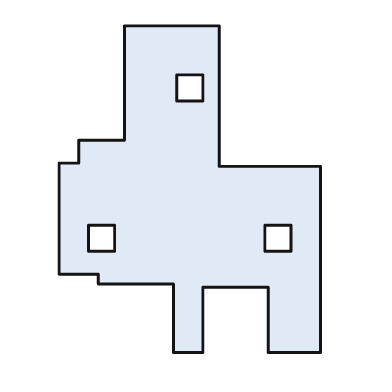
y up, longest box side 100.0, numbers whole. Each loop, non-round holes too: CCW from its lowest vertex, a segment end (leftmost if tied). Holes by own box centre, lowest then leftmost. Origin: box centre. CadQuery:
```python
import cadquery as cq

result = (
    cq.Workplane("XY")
    .moveTo(-5.0, -50.0)
    .lineTo(4.0, -50.0)
    .lineTo(4.0, -30.0)
    .lineTo(24.0, -30.0)
    .lineTo(24.0, -50.0)
    .lineTo(40.0, -50.0)
    .lineTo(40.0, 7.0)
    .lineTo(9.0, 7.0)
    .lineTo(9.0, 50.0)
    .lineTo(-20.0, 50.0)
    .lineTo(-20.0, 15.0)
    .lineTo(-34.0, 15.0)
    .lineTo(-34.0, 8.0)
    .lineTo(-40.0, 8.0)
    .lineTo(-40.0, -26.0)
    .lineTo(-28.0, -26.0)
    .lineTo(-28.0, -29.0)
    .lineTo(-5.0, -29.0)
    .close()
    .moveTo(-31.0, -19.0)
    .lineTo(-23.0, -19.0)
    .lineTo(-23.0, -11.0)
    .lineTo(-31.0, -11.0)
    .close()
    .moveTo(23.0, -19.0)
    .lineTo(31.0, -19.0)
    .lineTo(31.0, -11.0)
    .lineTo(23.0, -11.0)
    .close()
    .moveTo(-4.0, 27.0)
    .lineTo(4.0, 27.0)
    .lineTo(4.0, 35.0)
    .lineTo(-4.0, 35.0)
    .close()
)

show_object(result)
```